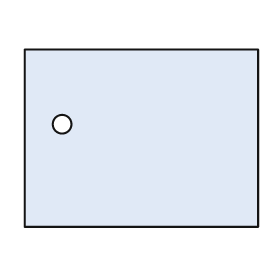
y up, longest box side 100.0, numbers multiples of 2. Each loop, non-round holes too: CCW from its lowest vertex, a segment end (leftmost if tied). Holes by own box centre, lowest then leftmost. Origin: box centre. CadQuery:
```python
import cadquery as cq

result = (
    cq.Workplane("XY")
    .moveTo(-50.0, -38.0)
    .lineTo(50.0, -38.0)
    .lineTo(50.0, 38.0)
    .lineTo(-50.0, 38.0)
    .close()
    .moveTo(-34.0, 6.0)
    .circle(4.0)
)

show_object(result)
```